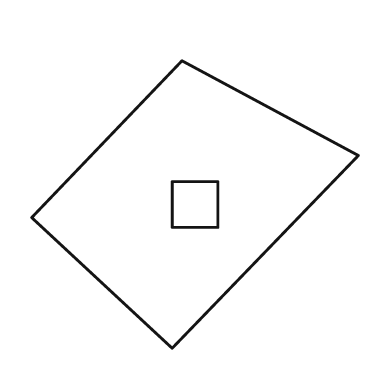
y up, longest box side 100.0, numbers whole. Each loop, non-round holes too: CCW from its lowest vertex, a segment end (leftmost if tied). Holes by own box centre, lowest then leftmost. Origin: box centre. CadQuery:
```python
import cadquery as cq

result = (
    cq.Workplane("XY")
    .moveTo(-7.0, -44.0)
    .lineTo(50.0, 15.0)
    .lineTo(-4.0, 44.0)
    .lineTo(-50.0, -4.0)
    .close()
    .moveTo(-7.0, -7.0)
    .lineTo(7.0, -7.0)
    .lineTo(7.0, 7.0)
    .lineTo(-7.0, 7.0)
    .close()
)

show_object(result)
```